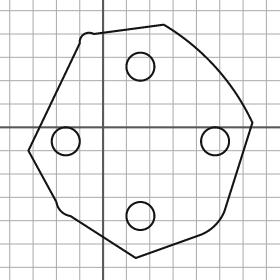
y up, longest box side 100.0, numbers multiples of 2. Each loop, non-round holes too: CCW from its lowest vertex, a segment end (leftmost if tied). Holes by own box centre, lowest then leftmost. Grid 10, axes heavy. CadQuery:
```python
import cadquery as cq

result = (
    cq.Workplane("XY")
    .moveTo(14.0, -56.0)
    .lineTo(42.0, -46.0)
    .threePointArc((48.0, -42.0), (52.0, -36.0))
    .lineTo(64.0, 2.0)
    .threePointArc((48.0, 26.0), (26.0, 44.0))
    .lineTo(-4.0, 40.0)
    .threePointArc((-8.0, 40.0), (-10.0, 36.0))
    .lineTo(-32.0, -10.0)
    .lineTo(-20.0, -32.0)
    .threePointArc((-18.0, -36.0), (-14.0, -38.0))
    .close()
    .moveTo(16.0, -38.0)
    .circle(6.0)
    .moveTo(-16.0, -6.0)
    .circle(6.0)
    .moveTo(48.0, -6.0)
    .circle(6.0)
    .moveTo(16.0, 26.0)
    .circle(6.0)
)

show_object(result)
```